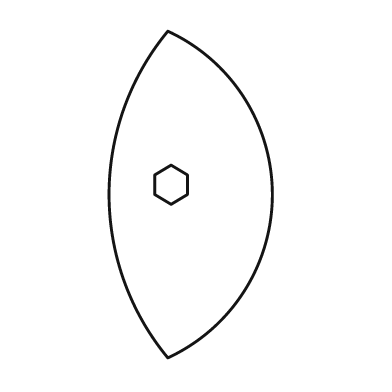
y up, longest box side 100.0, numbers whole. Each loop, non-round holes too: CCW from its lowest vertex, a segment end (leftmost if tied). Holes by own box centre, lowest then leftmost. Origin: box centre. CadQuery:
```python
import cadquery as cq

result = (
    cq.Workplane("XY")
    .moveTo(-7.0, -50.0)
    .threePointArc((25.0, 0.0), (-7.0, 50.0))
    .threePointArc((-25.0, 0.0), (-7.0, -50.0))
    .close()
    .moveTo(-6.0, -3.0)
    .lineTo(-1.0, 0.0)
    .lineTo(-1.0, 6.0)
    .lineTo(-6.0, 9.0)
    .lineTo(-11.0, 6.0)
    .lineTo(-11.0, 0.0)
    .close()
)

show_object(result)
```